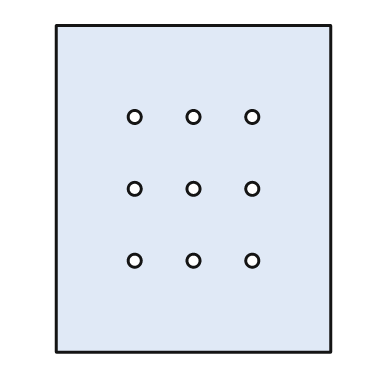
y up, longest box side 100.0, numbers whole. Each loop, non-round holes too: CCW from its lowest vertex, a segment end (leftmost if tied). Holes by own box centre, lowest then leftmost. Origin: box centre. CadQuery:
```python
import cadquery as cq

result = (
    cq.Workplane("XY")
    .moveTo(-42.0, -50.0)
    .lineTo(42.0, -50.0)
    .lineTo(42.0, 50.0)
    .lineTo(-42.0, 50.0)
    .close()
    .moveTo(-18.0, -22.0)
    .circle(2.0)
    .moveTo(0.0, -22.0)
    .circle(2.0)
    .moveTo(18.0, -22.0)
    .circle(2.0)
    .moveTo(-18.0, 0.0)
    .circle(2.0)
    .moveTo(0.0, 0.0)
    .circle(2.0)
    .moveTo(18.0, 0.0)
    .circle(2.0)
    .moveTo(-18.0, 22.0)
    .circle(2.0)
    .moveTo(0.0, 22.0)
    .circle(2.0)
    .moveTo(18.0, 22.0)
    .circle(2.0)
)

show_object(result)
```